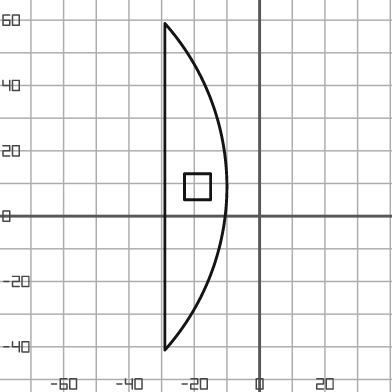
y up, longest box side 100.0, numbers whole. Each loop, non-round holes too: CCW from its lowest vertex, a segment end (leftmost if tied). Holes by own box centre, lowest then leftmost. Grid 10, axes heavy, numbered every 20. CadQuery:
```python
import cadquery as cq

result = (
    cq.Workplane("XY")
    .moveTo(-29.0, -41.0)
    .threePointArc((-10.0, 9.0), (-29.0, 59.0))
    .close()
    .moveTo(-23.0, 5.0)
    .lineTo(-15.0, 5.0)
    .lineTo(-15.0, 13.0)
    .lineTo(-23.0, 13.0)
    .close()
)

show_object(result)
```